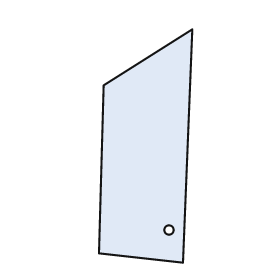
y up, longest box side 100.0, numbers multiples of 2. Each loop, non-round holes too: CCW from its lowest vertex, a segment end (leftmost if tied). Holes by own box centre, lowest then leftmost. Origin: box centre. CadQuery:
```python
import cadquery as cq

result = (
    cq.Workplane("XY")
    .moveTo(16.0, -50.0)
    .lineTo(20.0, 50.0)
    .lineTo(-18.0, 26.0)
    .lineTo(-20.0, -46.0)
    .close()
    .moveTo(10.0, -36.0)
    .circle(2.0)
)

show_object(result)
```